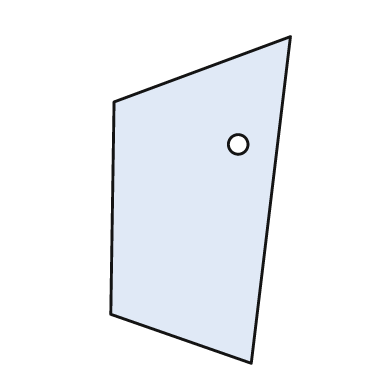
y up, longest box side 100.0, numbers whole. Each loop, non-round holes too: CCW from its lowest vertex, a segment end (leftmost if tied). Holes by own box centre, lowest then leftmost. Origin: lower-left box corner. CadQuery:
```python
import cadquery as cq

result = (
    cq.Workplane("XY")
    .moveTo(43.0, 0.0)
    .lineTo(55.0, 100.0)
    .lineTo(1.0, 80.0)
    .lineTo(0.0, 15.0)
    .close()
    .moveTo(39.0, 67.0)
    .circle(3.0)
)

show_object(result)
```